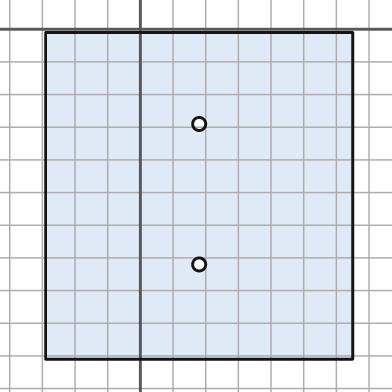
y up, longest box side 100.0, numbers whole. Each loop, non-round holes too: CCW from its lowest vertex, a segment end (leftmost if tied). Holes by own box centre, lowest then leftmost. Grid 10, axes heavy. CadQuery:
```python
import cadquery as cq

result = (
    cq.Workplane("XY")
    .moveTo(-29.0, -101.0)
    .lineTo(65.0, -101.0)
    .lineTo(65.0, -1.0)
    .lineTo(-29.0, -1.0)
    .close()
    .moveTo(18.0, -72.0)
    .circle(2.0)
    .moveTo(18.0, -29.0)
    .circle(2.0)
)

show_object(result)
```